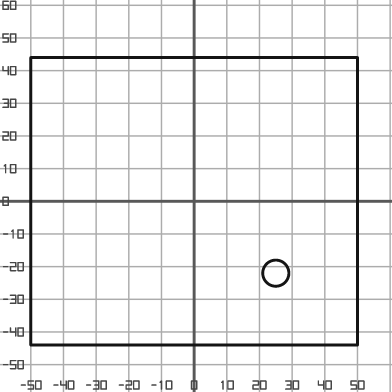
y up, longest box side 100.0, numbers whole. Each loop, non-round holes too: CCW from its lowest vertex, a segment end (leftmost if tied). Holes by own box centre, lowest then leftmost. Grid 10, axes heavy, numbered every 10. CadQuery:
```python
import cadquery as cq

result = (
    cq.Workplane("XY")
    .moveTo(-50.0, -44.0)
    .lineTo(50.0, -44.0)
    .lineTo(50.0, 44.0)
    .lineTo(-50.0, 44.0)
    .close()
    .moveTo(25.0, -22.0)
    .circle(4.0)
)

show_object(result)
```